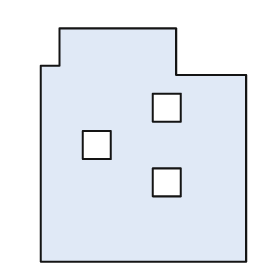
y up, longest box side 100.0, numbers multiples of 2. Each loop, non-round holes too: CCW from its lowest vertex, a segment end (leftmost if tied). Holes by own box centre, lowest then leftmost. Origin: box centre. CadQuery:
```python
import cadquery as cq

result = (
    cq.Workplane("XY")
    .moveTo(-44.0, -50.0)
    .lineTo(44.0, -50.0)
    .lineTo(44.0, 30.0)
    .lineTo(14.0, 30.0)
    .lineTo(14.0, 50.0)
    .lineTo(-36.0, 50.0)
    .lineTo(-36.0, 34.0)
    .lineTo(-44.0, 34.0)
    .close()
    .moveTo(4.0, -22.0)
    .lineTo(16.0, -22.0)
    .lineTo(16.0, -10.0)
    .lineTo(4.0, -10.0)
    .close()
    .moveTo(-26.0, -6.0)
    .lineTo(-14.0, -6.0)
    .lineTo(-14.0, 6.0)
    .lineTo(-26.0, 6.0)
    .close()
    .moveTo(4.0, 10.0)
    .lineTo(16.0, 10.0)
    .lineTo(16.0, 22.0)
    .lineTo(4.0, 22.0)
    .close()
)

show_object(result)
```